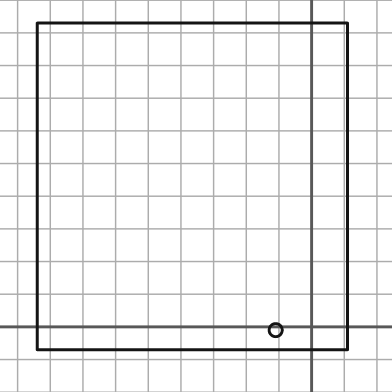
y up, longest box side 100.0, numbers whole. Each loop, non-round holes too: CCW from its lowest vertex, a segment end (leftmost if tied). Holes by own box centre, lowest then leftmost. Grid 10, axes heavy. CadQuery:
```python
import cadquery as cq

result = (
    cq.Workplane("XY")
    .moveTo(-84.0, -7.0)
    .lineTo(11.0, -7.0)
    .lineTo(11.0, 93.0)
    .lineTo(-84.0, 93.0)
    .close()
    .moveTo(-11.0, -1.0)
    .circle(2.0)
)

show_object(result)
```